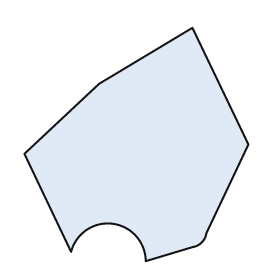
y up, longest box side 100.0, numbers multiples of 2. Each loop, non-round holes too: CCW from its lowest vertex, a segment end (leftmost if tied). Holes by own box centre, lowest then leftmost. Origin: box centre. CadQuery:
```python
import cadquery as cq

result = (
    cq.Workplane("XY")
    .moveTo(4.0, -50.0)
    .lineTo(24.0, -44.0)
    .threePointArc((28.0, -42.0), (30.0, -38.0))
    .lineTo(48.0, 0.0)
    .lineTo(24.0, 50.0)
    .lineTo(-16.0, 26.0)
    .lineTo(-48.0, -4.0)
    .lineTo(-28.0, -46.0)
    .threePointArc((-10.0, -34.0), (4.0, -50.0))
    .close()
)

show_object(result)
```